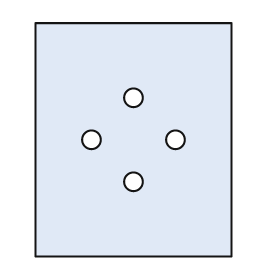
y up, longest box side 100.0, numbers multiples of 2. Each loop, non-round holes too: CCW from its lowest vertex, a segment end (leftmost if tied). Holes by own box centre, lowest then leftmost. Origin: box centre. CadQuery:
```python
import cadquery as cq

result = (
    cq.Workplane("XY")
    .moveTo(-42.0, -50.0)
    .lineTo(42.0, -50.0)
    .lineTo(42.0, 50.0)
    .lineTo(-42.0, 50.0)
    .close()
    .moveTo(0.0, -18.0)
    .circle(4.0)
    .moveTo(-18.0, 0.0)
    .circle(4.0)
    .moveTo(18.0, 0.0)
    .circle(4.0)
    .moveTo(0.0, 18.0)
    .circle(4.0)
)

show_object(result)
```